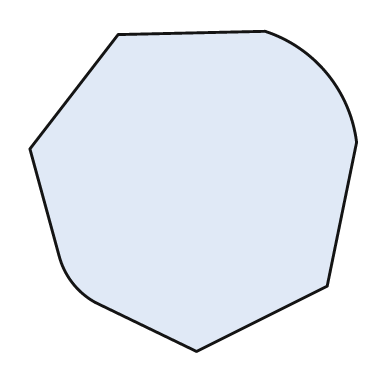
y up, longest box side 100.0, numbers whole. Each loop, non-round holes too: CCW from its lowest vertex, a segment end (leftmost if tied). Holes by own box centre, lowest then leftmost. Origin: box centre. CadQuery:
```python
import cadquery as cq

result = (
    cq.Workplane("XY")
    .moveTo(1.0, -49.0)
    .lineTo(41.0, -29.0)
    .lineTo(50.0, 15.0)
    .threePointArc((41.0, 36.0), (22.0, 49.0))
    .lineTo(-23.0, 48.0)
    .lineTo(-50.0, 13.0)
    .lineTo(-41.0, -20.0)
    .threePointArc((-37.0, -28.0), (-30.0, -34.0))
    .close()
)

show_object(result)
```